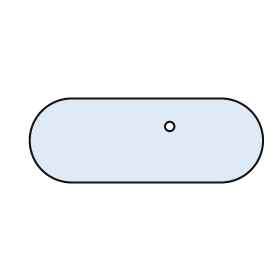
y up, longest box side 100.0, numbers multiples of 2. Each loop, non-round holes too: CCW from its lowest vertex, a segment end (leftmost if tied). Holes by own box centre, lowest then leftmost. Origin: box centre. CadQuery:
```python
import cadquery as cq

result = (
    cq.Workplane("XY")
    .moveTo(-32.0, -18.0)
    .lineTo(32.0, -18.0)
    .threePointArc((50.0, 0.0), (32.0, 18.0))
    .lineTo(-32.0, 18.0)
    .threePointArc((-50.0, 0.0), (-32.0, -18.0))
    .close()
    .moveTo(10.0, 6.0)
    .circle(2.0)
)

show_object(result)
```